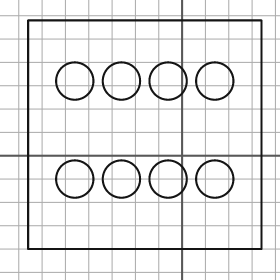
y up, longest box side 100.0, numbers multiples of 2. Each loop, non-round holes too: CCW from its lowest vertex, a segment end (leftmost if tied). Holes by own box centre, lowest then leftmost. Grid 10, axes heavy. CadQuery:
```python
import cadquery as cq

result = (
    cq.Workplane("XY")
    .moveTo(-66.0, -40.0)
    .lineTo(34.0, -40.0)
    .lineTo(34.0, 58.0)
    .lineTo(-66.0, 58.0)
    .close()
    .moveTo(-46.0, -10.0)
    .circle(8.0)
    .moveTo(-26.0, -10.0)
    .circle(8.0)
    .moveTo(-6.0, -10.0)
    .circle(8.0)
    .moveTo(14.0, -10.0)
    .circle(8.0)
    .moveTo(-46.0, 32.0)
    .circle(8.0)
    .moveTo(-26.0, 32.0)
    .circle(8.0)
    .moveTo(-6.0, 32.0)
    .circle(8.0)
    .moveTo(14.0, 32.0)
    .circle(8.0)
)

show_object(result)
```